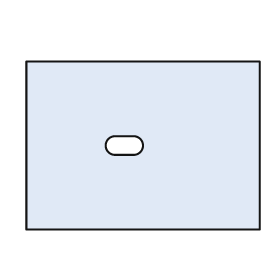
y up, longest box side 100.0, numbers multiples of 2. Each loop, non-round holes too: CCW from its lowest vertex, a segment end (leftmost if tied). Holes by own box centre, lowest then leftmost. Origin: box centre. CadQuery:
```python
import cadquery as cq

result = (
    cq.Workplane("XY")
    .moveTo(-50.0, -36.0)
    .lineTo(50.0, -36.0)
    .lineTo(50.0, 36.0)
    .lineTo(-50.0, 36.0)
    .close()
    .moveTo(-12.0, -4.0)
    .lineTo(-4.0, -4.0)
    .threePointArc((0.0, 0.0), (-4.0, 4.0))
    .lineTo(-12.0, 4.0)
    .threePointArc((-16.0, 0.0), (-12.0, -4.0))
    .close()
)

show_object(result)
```